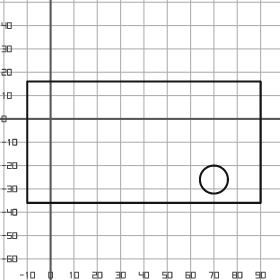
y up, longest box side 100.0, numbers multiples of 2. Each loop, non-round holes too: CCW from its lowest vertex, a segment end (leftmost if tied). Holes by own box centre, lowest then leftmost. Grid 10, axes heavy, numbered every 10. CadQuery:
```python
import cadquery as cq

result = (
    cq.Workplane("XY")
    .moveTo(-10.0, -36.0)
    .lineTo(90.0, -36.0)
    .lineTo(90.0, 16.0)
    .lineTo(-10.0, 16.0)
    .close()
    .moveTo(70.0, -26.0)
    .circle(6.0)
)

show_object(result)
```